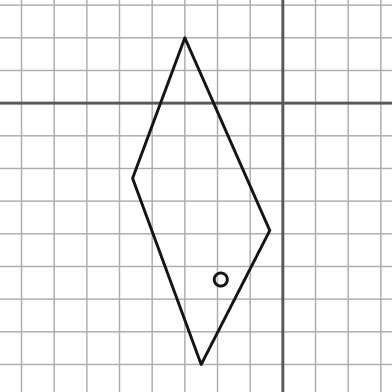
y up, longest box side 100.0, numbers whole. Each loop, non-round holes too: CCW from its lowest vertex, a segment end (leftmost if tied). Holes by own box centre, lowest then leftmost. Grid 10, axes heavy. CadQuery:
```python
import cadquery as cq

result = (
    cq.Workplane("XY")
    .moveTo(-25.0, -80.0)
    .lineTo(-4.0, -39.0)
    .lineTo(-30.0, 20.0)
    .lineTo(-46.0, -23.0)
    .close()
    .moveTo(-19.0, -54.0)
    .circle(2.0)
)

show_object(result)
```